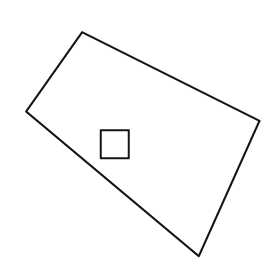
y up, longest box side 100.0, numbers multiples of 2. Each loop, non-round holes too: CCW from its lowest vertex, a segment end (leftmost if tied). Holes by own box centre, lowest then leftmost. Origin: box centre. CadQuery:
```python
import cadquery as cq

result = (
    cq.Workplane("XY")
    .moveTo(24.0, -48.0)
    .lineTo(50.0, 10.0)
    .lineTo(-26.0, 48.0)
    .lineTo(-50.0, 14.0)
    .close()
    .moveTo(-18.0, -6.0)
    .lineTo(-6.0, -6.0)
    .lineTo(-6.0, 6.0)
    .lineTo(-18.0, 6.0)
    .close()
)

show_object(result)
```